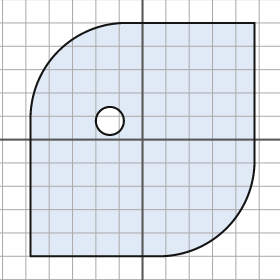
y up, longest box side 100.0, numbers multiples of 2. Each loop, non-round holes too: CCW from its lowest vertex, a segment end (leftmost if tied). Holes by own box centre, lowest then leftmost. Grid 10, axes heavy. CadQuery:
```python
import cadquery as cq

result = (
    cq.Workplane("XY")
    .moveTo(-48.0, -50.0)
    .lineTo(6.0, -50.0)
    .threePointArc((36.0, -38.0), (48.0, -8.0))
    .lineTo(48.0, 50.0)
    .lineTo(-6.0, 50.0)
    .threePointArc((-36.0, 38.0), (-48.0, 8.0))
    .close()
    .moveTo(-14.0, 8.0)
    .circle(6.0)
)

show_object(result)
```